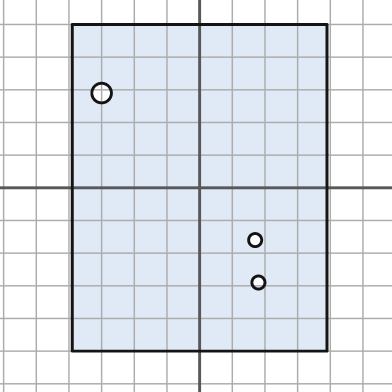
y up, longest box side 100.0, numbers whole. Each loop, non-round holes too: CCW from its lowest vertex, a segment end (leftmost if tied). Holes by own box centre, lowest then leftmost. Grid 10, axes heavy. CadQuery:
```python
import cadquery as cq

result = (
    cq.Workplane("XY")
    .moveTo(-39.0, -50.0)
    .lineTo(39.0, -50.0)
    .lineTo(39.0, 50.0)
    .lineTo(-39.0, 50.0)
    .close()
    .moveTo(18.0, -29.0)
    .circle(2.0)
    .moveTo(17.0, -16.0)
    .circle(2.0)
    .moveTo(-30.0, 29.0)
    .circle(3.0)
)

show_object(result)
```